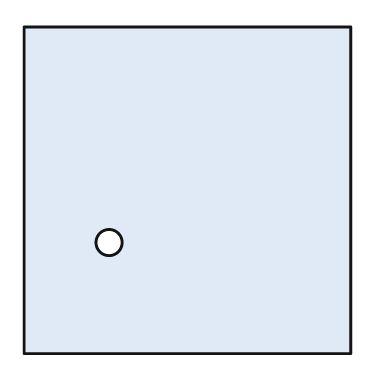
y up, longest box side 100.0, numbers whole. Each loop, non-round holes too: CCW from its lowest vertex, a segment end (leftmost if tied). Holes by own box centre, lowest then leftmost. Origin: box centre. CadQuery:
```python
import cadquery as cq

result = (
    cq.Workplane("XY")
    .moveTo(-50.0, -50.0)
    .lineTo(50.0, -50.0)
    .lineTo(50.0, 50.0)
    .lineTo(-50.0, 50.0)
    .close()
    .moveTo(-24.0, -16.0)
    .circle(4.0)
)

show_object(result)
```